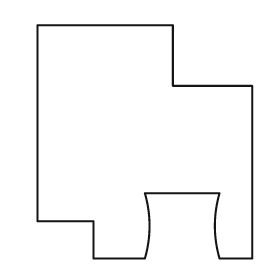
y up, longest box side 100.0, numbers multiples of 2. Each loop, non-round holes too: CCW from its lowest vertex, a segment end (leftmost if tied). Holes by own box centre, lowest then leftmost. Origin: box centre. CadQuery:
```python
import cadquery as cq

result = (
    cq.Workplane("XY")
    .moveTo(-22.0, -50.0)
    .lineTo(0.0, -50.0)
    .threePointArc((2.0, -36.0), (0.0, -22.0))
    .lineTo(32.0, -22.0)
    .threePointArc((30.0, -36.0), (32.0, -50.0))
    .lineTo(46.0, -50.0)
    .lineTo(46.0, 24.0)
    .lineTo(12.0, 24.0)
    .lineTo(12.0, 50.0)
    .lineTo(-46.0, 50.0)
    .lineTo(-46.0, -34.0)
    .lineTo(-22.0, -34.0)
    .close()
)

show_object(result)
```